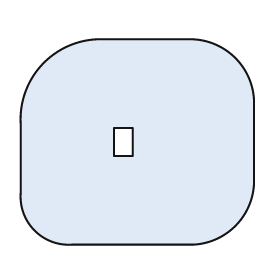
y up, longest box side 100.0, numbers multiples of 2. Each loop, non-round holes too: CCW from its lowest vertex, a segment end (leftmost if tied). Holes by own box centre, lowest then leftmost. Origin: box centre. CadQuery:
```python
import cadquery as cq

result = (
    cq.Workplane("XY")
    .moveTo(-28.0, -44.0)
    .lineTo(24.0, -44.0)
    .threePointArc((42.0, -36.0), (50.0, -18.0))
    .lineTo(50.0, 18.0)
    .threePointArc((42.0, 36.0), (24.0, 44.0))
    .lineTo(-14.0, 44.0)
    .threePointArc((-40.0, 34.0), (-50.0, 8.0))
    .lineTo(-50.0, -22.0)
    .threePointArc((-44.0, -38.0), (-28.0, -44.0))
    .close()
    .moveTo(-10.0, -6.0)
    .lineTo(-2.0, -6.0)
    .lineTo(-2.0, 6.0)
    .lineTo(-10.0, 6.0)
    .close()
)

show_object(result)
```